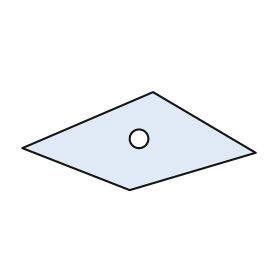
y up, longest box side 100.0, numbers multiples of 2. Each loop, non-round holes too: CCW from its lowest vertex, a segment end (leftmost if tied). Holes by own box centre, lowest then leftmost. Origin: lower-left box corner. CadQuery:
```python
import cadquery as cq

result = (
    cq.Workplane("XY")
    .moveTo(46.0, 0.0)
    .lineTo(100.0, 16.0)
    .lineTo(56.0, 42.0)
    .lineTo(0.0, 18.0)
    .close()
    .moveTo(50.0, 22.0)
    .circle(4.0)
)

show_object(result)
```